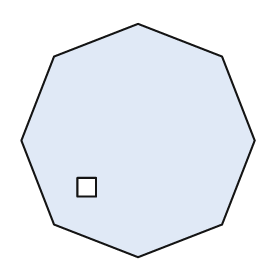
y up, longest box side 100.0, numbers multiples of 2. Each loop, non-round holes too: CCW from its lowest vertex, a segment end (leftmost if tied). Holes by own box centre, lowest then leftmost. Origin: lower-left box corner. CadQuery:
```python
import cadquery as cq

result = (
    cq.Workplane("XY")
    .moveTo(50.0, 0.0)
    .lineTo(86.0, 14.0)
    .lineTo(100.0, 50.0)
    .lineTo(86.0, 86.0)
    .lineTo(50.0, 100.0)
    .lineTo(14.0, 86.0)
    .lineTo(0.0, 50.0)
    .lineTo(14.0, 14.0)
    .close()
    .moveTo(24.0, 26.0)
    .lineTo(32.0, 26.0)
    .lineTo(32.0, 34.0)
    .lineTo(24.0, 34.0)
    .close()
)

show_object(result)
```